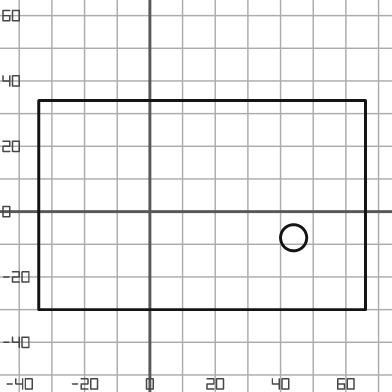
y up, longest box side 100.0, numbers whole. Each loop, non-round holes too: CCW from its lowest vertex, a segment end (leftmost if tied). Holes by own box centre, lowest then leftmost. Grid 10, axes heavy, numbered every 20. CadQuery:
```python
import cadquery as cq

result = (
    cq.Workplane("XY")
    .moveTo(-34.0, -30.0)
    .lineTo(66.0, -30.0)
    .lineTo(66.0, 34.0)
    .lineTo(-34.0, 34.0)
    .close()
    .moveTo(44.0, -8.0)
    .circle(4.0)
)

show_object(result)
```